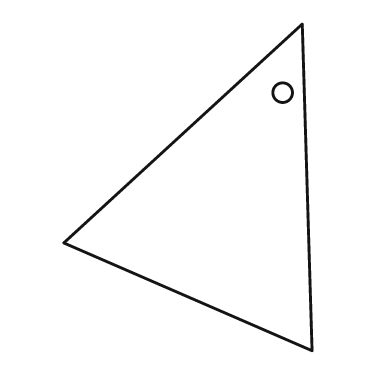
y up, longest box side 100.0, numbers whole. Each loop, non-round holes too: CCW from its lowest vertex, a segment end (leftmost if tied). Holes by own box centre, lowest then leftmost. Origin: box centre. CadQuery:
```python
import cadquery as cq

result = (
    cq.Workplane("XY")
    .moveTo(38.0, -50.0)
    .lineTo(35.0, 50.0)
    .lineTo(-38.0, -17.0)
    .close()
    .moveTo(29.0, 29.0)
    .circle(3.0)
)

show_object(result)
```